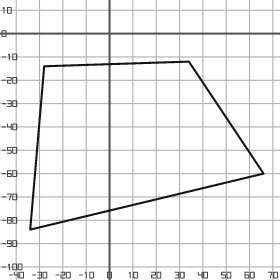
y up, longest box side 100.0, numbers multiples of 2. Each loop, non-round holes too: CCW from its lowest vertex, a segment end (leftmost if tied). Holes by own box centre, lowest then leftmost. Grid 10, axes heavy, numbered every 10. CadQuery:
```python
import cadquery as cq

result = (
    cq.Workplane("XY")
    .moveTo(-34.0, -84.0)
    .lineTo(66.0, -60.0)
    .lineTo(34.0, -12.0)
    .lineTo(-28.0, -14.0)
    .close()
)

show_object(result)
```